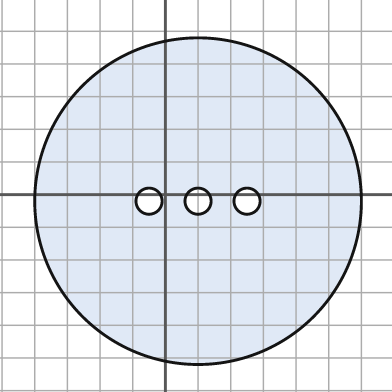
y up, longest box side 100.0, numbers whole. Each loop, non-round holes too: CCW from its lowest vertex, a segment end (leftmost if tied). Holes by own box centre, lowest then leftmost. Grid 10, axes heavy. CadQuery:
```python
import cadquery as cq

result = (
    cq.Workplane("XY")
    .moveTo(10.0, -2.0)
    .circle(50.0)
    .moveTo(-5.0, -2.0)
    .circle(4.0)
    .moveTo(10.0, -2.0)
    .circle(4.0)
    .moveTo(25.0, -2.0)
    .circle(4.0)
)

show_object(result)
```